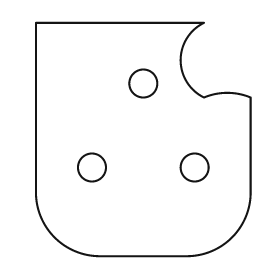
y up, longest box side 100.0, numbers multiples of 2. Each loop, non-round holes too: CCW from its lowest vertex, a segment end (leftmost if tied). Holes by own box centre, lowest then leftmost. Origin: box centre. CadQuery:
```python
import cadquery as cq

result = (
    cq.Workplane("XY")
    .moveTo(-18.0, -50.0)
    .lineTo(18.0, -50.0)
    .threePointArc((38.0, -42.0), (46.0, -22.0))
    .lineTo(46.0, 18.0)
    .threePointArc((36.0, 20.0), (26.0, 18.0))
    .threePointArc((16.0, 34.0), (26.0, 50.0))
    .lineTo(-46.0, 50.0)
    .lineTo(-46.0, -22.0)
    .threePointArc((-38.0, -42.0), (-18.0, -50.0))
    .close()
    .moveTo(-22.0, -12.0)
    .circle(6.0)
    .moveTo(22.0, -12.0)
    .circle(6.0)
    .moveTo(0.0, 24.0)
    .circle(6.0)
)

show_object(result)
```